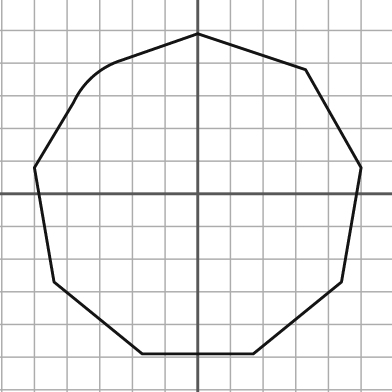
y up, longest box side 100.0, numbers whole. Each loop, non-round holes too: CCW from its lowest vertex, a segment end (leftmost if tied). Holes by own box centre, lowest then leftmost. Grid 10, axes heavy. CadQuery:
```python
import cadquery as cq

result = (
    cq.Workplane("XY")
    .moveTo(-17.0, -49.0)
    .lineTo(17.0, -49.0)
    .lineTo(44.0, -27.0)
    .lineTo(50.0, 8.0)
    .lineTo(33.0, 38.0)
    .lineTo(0.0, 49.0)
    .lineTo(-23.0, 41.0)
    .threePointArc((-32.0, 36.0), (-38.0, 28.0))
    .lineTo(-50.0, 8.0)
    .lineTo(-44.0, -27.0)
    .close()
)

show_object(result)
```